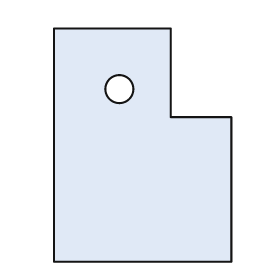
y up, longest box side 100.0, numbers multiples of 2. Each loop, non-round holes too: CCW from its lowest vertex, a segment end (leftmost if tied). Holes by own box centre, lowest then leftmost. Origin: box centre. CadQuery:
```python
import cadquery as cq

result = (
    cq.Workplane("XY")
    .moveTo(-38.0, -50.0)
    .lineTo(38.0, -50.0)
    .lineTo(38.0, 12.0)
    .lineTo(12.0, 12.0)
    .lineTo(12.0, 50.0)
    .lineTo(-38.0, 50.0)
    .close()
    .moveTo(-10.0, 24.0)
    .circle(6.0)
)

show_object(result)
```